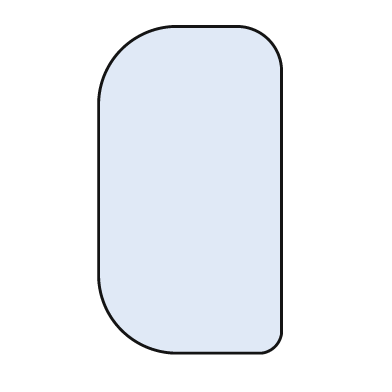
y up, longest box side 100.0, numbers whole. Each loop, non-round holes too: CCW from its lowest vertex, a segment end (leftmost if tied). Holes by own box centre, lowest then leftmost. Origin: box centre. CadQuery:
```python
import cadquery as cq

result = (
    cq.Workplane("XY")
    .moveTo(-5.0, -50.0)
    .lineTo(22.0, -50.0)
    .threePointArc((26.0, -48.0), (28.0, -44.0))
    .lineTo(28.0, 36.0)
    .threePointArc((24.0, 46.0), (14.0, 50.0))
    .lineTo(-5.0, 50.0)
    .threePointArc((-21.0, 43.0), (-28.0, 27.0))
    .lineTo(-28.0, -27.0)
    .threePointArc((-21.0, -43.0), (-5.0, -50.0))
    .close()
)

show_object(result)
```